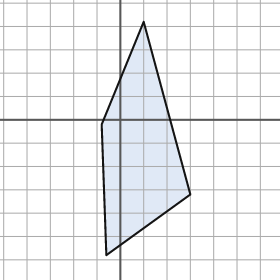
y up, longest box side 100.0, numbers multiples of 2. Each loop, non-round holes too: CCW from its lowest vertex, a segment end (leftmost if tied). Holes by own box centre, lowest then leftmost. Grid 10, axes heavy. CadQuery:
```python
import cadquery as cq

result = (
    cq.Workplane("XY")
    .moveTo(-6.0, -58.0)
    .lineTo(30.0, -32.0)
    .lineTo(10.0, 42.0)
    .lineTo(-8.0, -2.0)
    .close()
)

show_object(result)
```